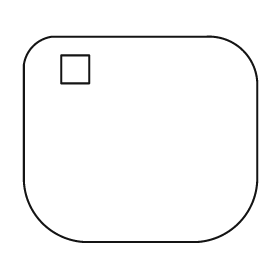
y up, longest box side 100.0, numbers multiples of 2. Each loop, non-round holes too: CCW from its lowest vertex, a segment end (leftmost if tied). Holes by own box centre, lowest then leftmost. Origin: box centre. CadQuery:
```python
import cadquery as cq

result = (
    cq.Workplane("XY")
    .moveTo(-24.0, -44.0)
    .lineTo(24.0, -44.0)
    .threePointArc((42.0, -36.0), (50.0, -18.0))
    .lineTo(50.0, 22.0)
    .threePointArc((44.0, 38.0), (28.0, 44.0))
    .lineTo(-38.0, 44.0)
    .threePointArc((-46.0, 40.0), (-50.0, 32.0))
    .lineTo(-50.0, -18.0)
    .threePointArc((-42.0, -36.0), (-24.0, -44.0))
    .close()
    .moveTo(-34.0, 24.0)
    .lineTo(-22.0, 24.0)
    .lineTo(-22.0, 36.0)
    .lineTo(-34.0, 36.0)
    .close()
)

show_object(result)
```